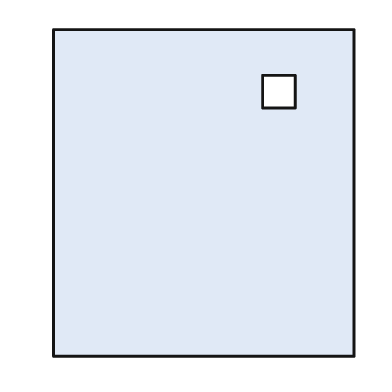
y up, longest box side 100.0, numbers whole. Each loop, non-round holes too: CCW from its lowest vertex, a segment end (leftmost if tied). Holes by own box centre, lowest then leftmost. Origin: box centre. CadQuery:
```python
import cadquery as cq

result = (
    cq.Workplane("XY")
    .moveTo(-46.0, -50.0)
    .lineTo(46.0, -50.0)
    .lineTo(46.0, 50.0)
    .lineTo(-46.0, 50.0)
    .close()
    .moveTo(18.0, 26.0)
    .lineTo(28.0, 26.0)
    .lineTo(28.0, 36.0)
    .lineTo(18.0, 36.0)
    .close()
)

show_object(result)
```